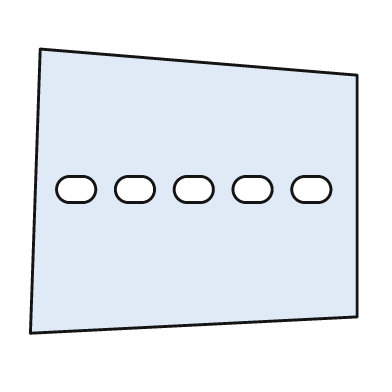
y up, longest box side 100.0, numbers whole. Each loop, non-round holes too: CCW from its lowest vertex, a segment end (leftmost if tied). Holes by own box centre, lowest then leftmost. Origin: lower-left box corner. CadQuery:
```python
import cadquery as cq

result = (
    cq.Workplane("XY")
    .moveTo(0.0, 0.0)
    .lineTo(100.0, 5.0)
    .lineTo(100.0, 79.0)
    .lineTo(3.0, 87.0)
    .close()
    .moveTo(12.0, 40.0)
    .lineTo(16.0, 40.0)
    .threePointArc((20.0, 44.0), (16.0, 48.0))
    .lineTo(12.0, 48.0)
    .threePointArc((8.0, 44.0), (12.0, 40.0))
    .close()
    .moveTo(30.0, 40.0)
    .lineTo(34.0, 40.0)
    .threePointArc((38.0, 44.0), (34.0, 48.0))
    .lineTo(30.0, 48.0)
    .threePointArc((26.0, 44.0), (30.0, 40.0))
    .close()
    .moveTo(48.0, 40.0)
    .lineTo(52.0, 40.0)
    .threePointArc((56.0, 44.0), (52.0, 48.0))
    .lineTo(48.0, 48.0)
    .threePointArc((44.0, 44.0), (48.0, 40.0))
    .close()
    .moveTo(66.0, 40.0)
    .lineTo(70.0, 40.0)
    .threePointArc((74.0, 44.0), (70.0, 48.0))
    .lineTo(66.0, 48.0)
    .threePointArc((62.0, 44.0), (66.0, 40.0))
    .close()
    .moveTo(84.0, 40.0)
    .lineTo(88.0, 40.0)
    .threePointArc((92.0, 44.0), (88.0, 48.0))
    .lineTo(84.0, 48.0)
    .threePointArc((80.0, 44.0), (84.0, 40.0))
    .close()
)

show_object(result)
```